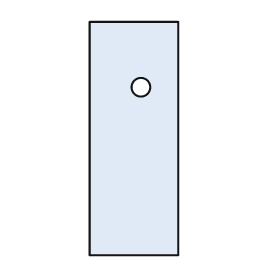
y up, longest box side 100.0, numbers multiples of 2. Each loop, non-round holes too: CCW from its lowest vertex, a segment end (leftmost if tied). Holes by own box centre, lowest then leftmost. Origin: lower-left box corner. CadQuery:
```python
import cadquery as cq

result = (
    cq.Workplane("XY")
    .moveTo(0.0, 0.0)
    .lineTo(38.0, 0.0)
    .lineTo(38.0, 100.0)
    .lineTo(0.0, 100.0)
    .close()
    .moveTo(22.0, 72.0)
    .circle(4.0)
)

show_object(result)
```